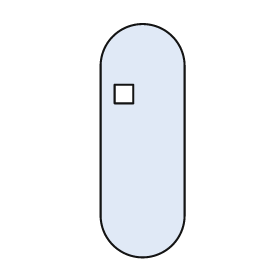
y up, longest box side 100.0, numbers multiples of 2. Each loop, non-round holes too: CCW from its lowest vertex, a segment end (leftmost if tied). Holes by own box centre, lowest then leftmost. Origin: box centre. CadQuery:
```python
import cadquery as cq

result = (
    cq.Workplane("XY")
    .moveTo(-18.0, -32.0)
    .threePointArc((0.0, -50.0), (18.0, -32.0))
    .lineTo(18.0, 32.0)
    .threePointArc((0.0, 50.0), (-18.0, 32.0))
    .close()
    .moveTo(-12.0, 16.0)
    .lineTo(-4.0, 16.0)
    .lineTo(-4.0, 24.0)
    .lineTo(-12.0, 24.0)
    .close()
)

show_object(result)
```